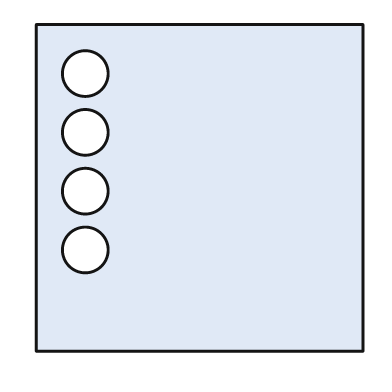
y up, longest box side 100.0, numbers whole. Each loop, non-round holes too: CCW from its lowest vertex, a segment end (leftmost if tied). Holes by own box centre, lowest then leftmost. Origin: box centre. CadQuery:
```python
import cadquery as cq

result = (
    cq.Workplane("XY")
    .moveTo(-50.0, -50.0)
    .lineTo(50.0, -50.0)
    .lineTo(50.0, 50.0)
    .lineTo(-50.0, 50.0)
    .close()
    .moveTo(-35.0, -19.0)
    .circle(7.0)
    .moveTo(-35.0, -1.0)
    .circle(7.0)
    .moveTo(-35.0, 17.0)
    .circle(7.0)
    .moveTo(-35.0, 35.0)
    .circle(7.0)
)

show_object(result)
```